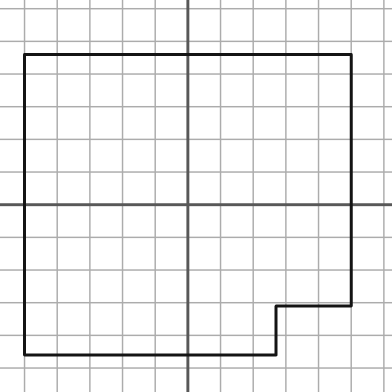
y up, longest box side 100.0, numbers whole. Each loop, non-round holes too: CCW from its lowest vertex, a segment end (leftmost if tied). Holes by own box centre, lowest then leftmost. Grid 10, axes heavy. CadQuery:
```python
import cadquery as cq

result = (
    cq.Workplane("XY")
    .moveTo(-50.0, -46.0)
    .lineTo(27.0, -46.0)
    .lineTo(27.0, -31.0)
    .lineTo(50.0, -31.0)
    .lineTo(50.0, 46.0)
    .lineTo(-50.0, 46.0)
    .close()
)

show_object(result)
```